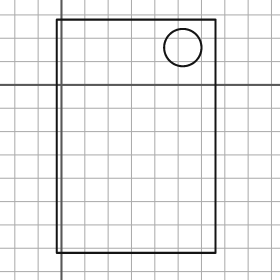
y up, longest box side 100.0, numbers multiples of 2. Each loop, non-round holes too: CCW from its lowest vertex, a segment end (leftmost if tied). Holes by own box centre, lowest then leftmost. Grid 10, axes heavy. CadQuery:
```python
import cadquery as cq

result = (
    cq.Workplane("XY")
    .moveTo(-2.0, -72.0)
    .lineTo(66.0, -72.0)
    .lineTo(66.0, 28.0)
    .lineTo(-2.0, 28.0)
    .close()
    .moveTo(52.0, 16.0)
    .circle(8.0)
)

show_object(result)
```